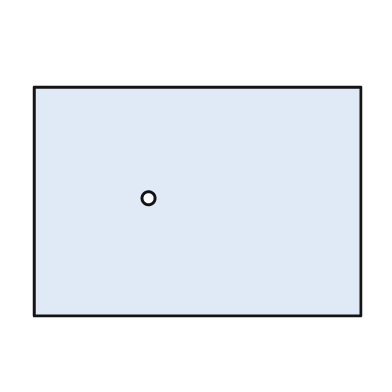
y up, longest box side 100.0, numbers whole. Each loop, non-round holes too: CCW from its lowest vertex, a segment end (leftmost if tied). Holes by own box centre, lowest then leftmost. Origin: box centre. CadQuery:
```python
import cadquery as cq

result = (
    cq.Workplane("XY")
    .moveTo(-50.0, -35.0)
    .lineTo(50.0, -35.0)
    .lineTo(50.0, 35.0)
    .lineTo(-50.0, 35.0)
    .close()
    .moveTo(-15.0, 1.0)
    .circle(2.0)
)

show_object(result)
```